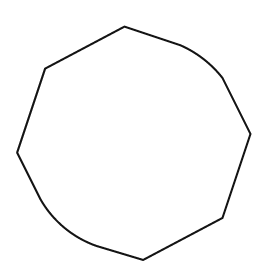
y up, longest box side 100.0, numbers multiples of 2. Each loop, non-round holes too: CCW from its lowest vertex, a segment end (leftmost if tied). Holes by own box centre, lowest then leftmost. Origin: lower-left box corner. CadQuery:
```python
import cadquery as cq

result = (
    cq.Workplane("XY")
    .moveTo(54.0, 0.0)
    .lineTo(88.0, 18.0)
    .lineTo(100.0, 54.0)
    .lineTo(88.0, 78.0)
    .threePointArc((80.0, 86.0), (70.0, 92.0))
    .lineTo(46.0, 100.0)
    .lineTo(12.0, 82.0)
    .lineTo(0.0, 46.0)
    .lineTo(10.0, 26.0)
    .threePointArc((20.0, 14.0), (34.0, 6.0))
    .close()
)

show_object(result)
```